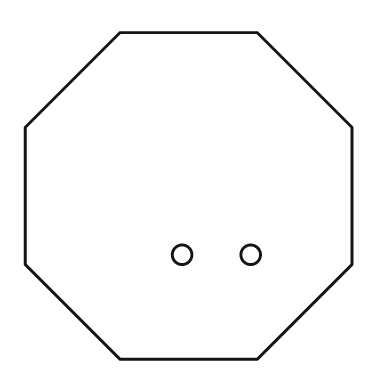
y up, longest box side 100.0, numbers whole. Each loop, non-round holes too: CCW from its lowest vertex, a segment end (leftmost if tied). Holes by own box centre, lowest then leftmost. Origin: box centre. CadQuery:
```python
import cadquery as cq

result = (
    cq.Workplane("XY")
    .moveTo(-21.0, -50.0)
    .lineTo(21.0, -50.0)
    .lineTo(50.0, -21.0)
    .lineTo(50.0, 21.0)
    .lineTo(21.0, 50.0)
    .lineTo(-21.0, 50.0)
    .lineTo(-50.0, 21.0)
    .lineTo(-50.0, -21.0)
    .close()
    .moveTo(-2.0, -18.0)
    .circle(3.0)
    .moveTo(19.0, -18.0)
    .circle(3.0)
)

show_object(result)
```